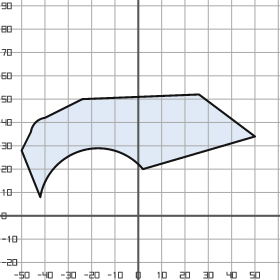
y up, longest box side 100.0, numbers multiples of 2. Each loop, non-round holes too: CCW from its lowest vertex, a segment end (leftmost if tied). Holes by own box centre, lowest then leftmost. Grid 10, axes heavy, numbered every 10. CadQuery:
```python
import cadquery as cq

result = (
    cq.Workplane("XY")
    .moveTo(-42.0, 8.0)
    .threePointArc((-24.0, 28.0), (2.0, 20.0))
    .lineTo(50.0, 34.0)
    .lineTo(26.0, 52.0)
    .lineTo(-24.0, 50.0)
    .lineTo(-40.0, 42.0)
    .threePointArc((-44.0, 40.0), (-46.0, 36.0))
    .lineTo(-50.0, 28.0)
    .close()
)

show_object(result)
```